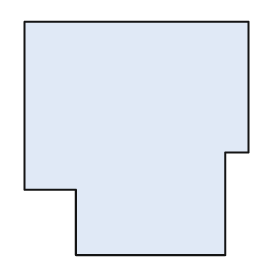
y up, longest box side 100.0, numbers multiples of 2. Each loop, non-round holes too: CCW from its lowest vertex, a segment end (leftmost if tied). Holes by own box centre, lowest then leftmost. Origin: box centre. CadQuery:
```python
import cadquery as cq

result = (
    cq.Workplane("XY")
    .moveTo(-26.0, -50.0)
    .lineTo(38.0, -50.0)
    .lineTo(38.0, -6.0)
    .lineTo(48.0, -6.0)
    .lineTo(48.0, 50.0)
    .lineTo(-48.0, 50.0)
    .lineTo(-48.0, -22.0)
    .lineTo(-26.0, -22.0)
    .close()
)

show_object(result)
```